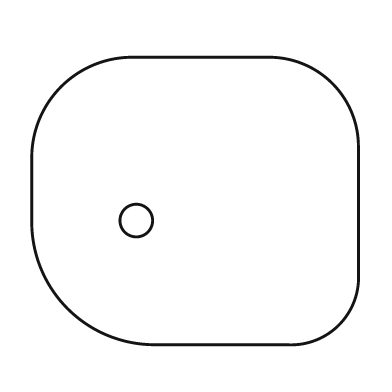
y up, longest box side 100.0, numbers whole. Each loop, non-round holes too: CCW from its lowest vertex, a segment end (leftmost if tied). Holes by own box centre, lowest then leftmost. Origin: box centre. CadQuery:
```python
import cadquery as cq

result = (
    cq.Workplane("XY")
    .moveTo(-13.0, -44.0)
    .lineTo(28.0, -44.0)
    .threePointArc((44.0, -38.0), (50.0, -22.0))
    .lineTo(50.0, 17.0)
    .threePointArc((42.0, 36.0), (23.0, 44.0))
    .lineTo(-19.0, 44.0)
    .threePointArc((-41.0, 35.0), (-50.0, 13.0))
    .lineTo(-50.0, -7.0)
    .threePointArc((-39.0, -33.0), (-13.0, -44.0))
    .close()
    .moveTo(-18.0, -6.0)
    .circle(5.0)
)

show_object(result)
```